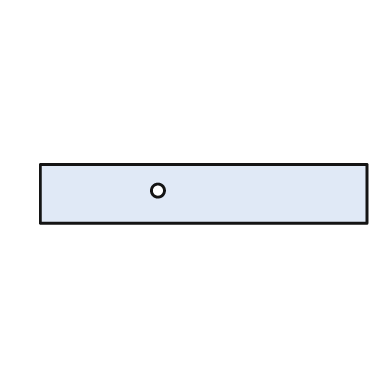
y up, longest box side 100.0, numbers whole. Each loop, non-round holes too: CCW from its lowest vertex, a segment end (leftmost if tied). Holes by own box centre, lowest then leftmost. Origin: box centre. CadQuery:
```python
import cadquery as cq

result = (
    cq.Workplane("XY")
    .moveTo(-50.0, -9.0)
    .lineTo(50.0, -9.0)
    .lineTo(50.0, 9.0)
    .lineTo(-50.0, 9.0)
    .close()
    .moveTo(-14.0, 1.0)
    .circle(2.0)
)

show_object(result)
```